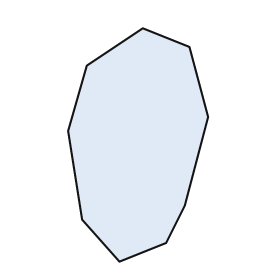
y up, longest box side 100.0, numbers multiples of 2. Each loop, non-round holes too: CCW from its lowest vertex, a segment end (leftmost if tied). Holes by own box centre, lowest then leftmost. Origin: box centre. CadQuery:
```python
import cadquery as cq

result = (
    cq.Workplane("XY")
    .moveTo(-8.0, -50.0)
    .lineTo(12.0, -42.0)
    .lineTo(20.0, -26.0)
    .lineTo(30.0, 12.0)
    .lineTo(22.0, 42.0)
    .lineTo(2.0, 50.0)
    .lineTo(-22.0, 34.0)
    .lineTo(-30.0, 6.0)
    .lineTo(-24.0, -32.0)
    .close()
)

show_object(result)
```